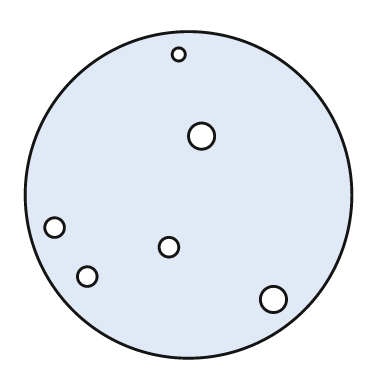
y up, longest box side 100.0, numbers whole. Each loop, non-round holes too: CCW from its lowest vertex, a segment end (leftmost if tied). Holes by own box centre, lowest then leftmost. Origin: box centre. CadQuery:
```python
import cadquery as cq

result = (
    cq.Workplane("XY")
    .moveTo(0.0, 0.0)
    .circle(50.0)
    .moveTo(26.0, -32.0)
    .circle(4.0)
    .moveTo(-31.0, -25.0)
    .circle(3.0)
    .moveTo(-6.0, -16.0)
    .circle(3.0)
    .moveTo(-41.0, -10.0)
    .circle(3.0)
    .moveTo(4.0, 18.0)
    .circle(4.0)
    .moveTo(-3.0, 43.0)
    .circle(2.0)
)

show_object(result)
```